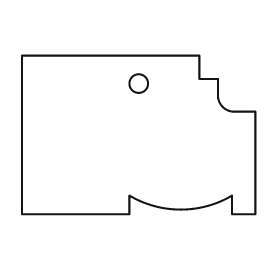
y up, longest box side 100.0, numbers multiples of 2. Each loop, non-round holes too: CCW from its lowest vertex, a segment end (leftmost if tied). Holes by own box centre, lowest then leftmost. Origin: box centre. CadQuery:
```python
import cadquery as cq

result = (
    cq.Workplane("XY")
    .moveTo(-50.0, -34.0)
    .lineTo(-4.0, -34.0)
    .lineTo(-4.0, -26.0)
    .threePointArc((18.0, -32.0), (40.0, -26.0))
    .lineTo(40.0, -34.0)
    .lineTo(50.0, -34.0)
    .lineTo(50.0, 10.0)
    .lineTo(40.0, 10.0)
    .threePointArc((36.0, 12.0), (34.0, 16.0))
    .lineTo(34.0, 24.0)
    .lineTo(26.0, 24.0)
    .lineTo(26.0, 34.0)
    .lineTo(-50.0, 34.0)
    .close()
    .moveTo(0.0, 22.0)
    .circle(4.0)
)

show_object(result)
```